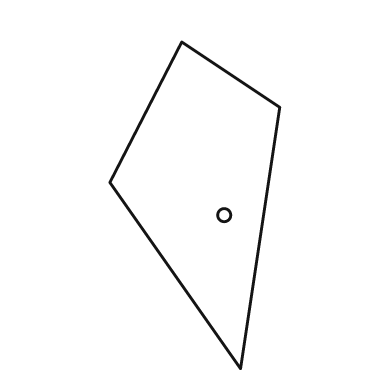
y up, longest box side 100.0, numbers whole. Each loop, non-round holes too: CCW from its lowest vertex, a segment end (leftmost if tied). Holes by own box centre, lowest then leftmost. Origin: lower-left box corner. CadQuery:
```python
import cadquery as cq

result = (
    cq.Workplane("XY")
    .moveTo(40.0, 0.0)
    .lineTo(52.0, 80.0)
    .lineTo(22.0, 100.0)
    .lineTo(0.0, 57.0)
    .close()
    .moveTo(35.0, 47.0)
    .circle(2.0)
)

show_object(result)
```